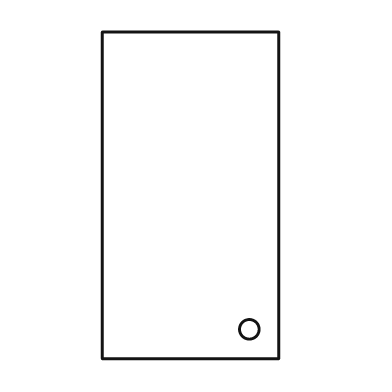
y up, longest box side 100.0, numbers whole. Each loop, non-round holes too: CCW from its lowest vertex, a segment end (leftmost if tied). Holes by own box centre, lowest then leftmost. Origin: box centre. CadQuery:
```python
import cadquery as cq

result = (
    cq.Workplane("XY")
    .moveTo(-27.0, -50.0)
    .lineTo(27.0, -50.0)
    .lineTo(27.0, 50.0)
    .lineTo(-27.0, 50.0)
    .close()
    .moveTo(18.0, -41.0)
    .circle(3.0)
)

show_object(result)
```